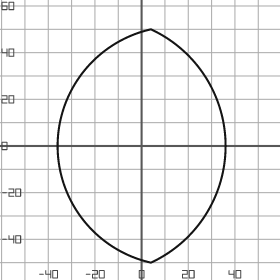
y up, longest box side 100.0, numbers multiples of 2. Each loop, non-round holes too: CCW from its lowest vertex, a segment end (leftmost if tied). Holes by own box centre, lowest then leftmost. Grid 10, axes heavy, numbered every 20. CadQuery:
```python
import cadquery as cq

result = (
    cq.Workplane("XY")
    .moveTo(4.0, -50.0)
    .threePointArc((36.0, 0.0), (4.0, 50.0))
    .threePointArc((-36.0, 0.0), (4.0, -50.0))
    .close()
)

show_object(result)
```